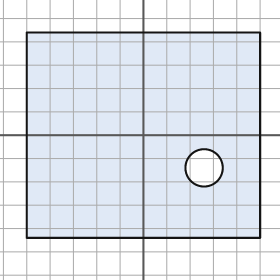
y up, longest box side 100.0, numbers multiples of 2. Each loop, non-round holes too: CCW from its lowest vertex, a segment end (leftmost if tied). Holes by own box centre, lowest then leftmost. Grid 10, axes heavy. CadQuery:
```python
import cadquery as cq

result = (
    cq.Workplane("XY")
    .moveTo(-50.0, -44.0)
    .lineTo(50.0, -44.0)
    .lineTo(50.0, 44.0)
    .lineTo(-50.0, 44.0)
    .close()
    .moveTo(26.0, -14.0)
    .circle(8.0)
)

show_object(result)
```